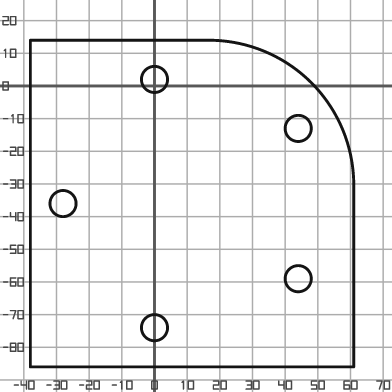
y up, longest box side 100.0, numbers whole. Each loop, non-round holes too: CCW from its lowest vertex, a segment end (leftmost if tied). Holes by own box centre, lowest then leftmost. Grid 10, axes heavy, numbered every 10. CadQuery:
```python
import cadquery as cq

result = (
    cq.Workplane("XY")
    .moveTo(-38.0, -86.0)
    .lineTo(61.0, -86.0)
    .lineTo(61.0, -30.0)
    .threePointArc((48.0, 1.0), (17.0, 14.0))
    .lineTo(-38.0, 14.0)
    .close()
    .moveTo(0.0, -74.0)
    .circle(4.0)
    .moveTo(44.0, -59.0)
    .circle(4.0)
    .moveTo(-28.0, -36.0)
    .circle(4.0)
    .moveTo(44.0, -13.0)
    .circle(4.0)
    .moveTo(0.0, 2.0)
    .circle(4.0)
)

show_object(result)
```